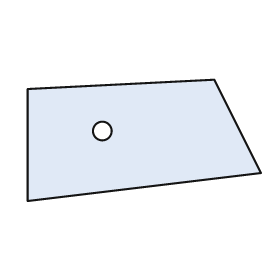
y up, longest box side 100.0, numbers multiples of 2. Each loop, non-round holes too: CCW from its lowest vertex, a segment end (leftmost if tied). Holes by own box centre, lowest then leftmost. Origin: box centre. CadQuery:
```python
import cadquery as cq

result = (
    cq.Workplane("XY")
    .moveTo(-50.0, -26.0)
    .lineTo(50.0, -14.0)
    .lineTo(30.0, 26.0)
    .lineTo(-50.0, 22.0)
    .close()
    .moveTo(-18.0, 4.0)
    .circle(4.0)
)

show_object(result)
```